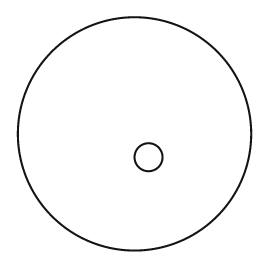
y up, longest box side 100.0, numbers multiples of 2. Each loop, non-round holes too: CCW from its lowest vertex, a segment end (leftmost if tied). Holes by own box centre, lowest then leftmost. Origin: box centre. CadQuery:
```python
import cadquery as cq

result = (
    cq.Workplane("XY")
    .moveTo(0.0, 0.0)
    .circle(50.0)
    .moveTo(6.0, -10.0)
    .circle(6.0)
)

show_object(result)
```